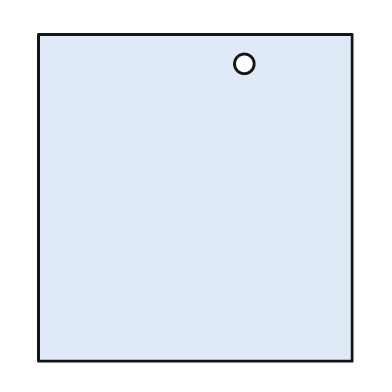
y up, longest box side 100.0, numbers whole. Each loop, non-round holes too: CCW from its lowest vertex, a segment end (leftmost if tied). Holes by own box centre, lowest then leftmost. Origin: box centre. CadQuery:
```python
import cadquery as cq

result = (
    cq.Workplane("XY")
    .moveTo(-48.0, -50.0)
    .lineTo(48.0, -50.0)
    .lineTo(48.0, 50.0)
    .lineTo(-48.0, 50.0)
    .close()
    .moveTo(15.0, 41.0)
    .circle(3.0)
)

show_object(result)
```